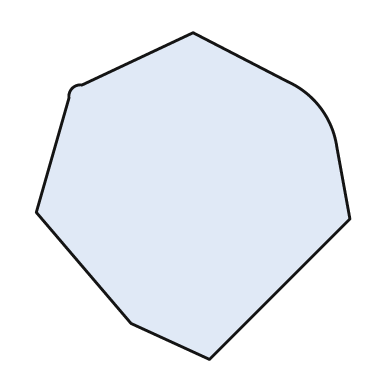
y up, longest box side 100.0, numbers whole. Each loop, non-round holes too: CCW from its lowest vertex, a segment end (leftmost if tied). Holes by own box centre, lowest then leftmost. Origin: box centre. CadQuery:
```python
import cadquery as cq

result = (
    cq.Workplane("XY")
    .moveTo(5.0, -50.0)
    .lineTo(48.0, -7.0)
    .lineTo(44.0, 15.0)
    .threePointArc((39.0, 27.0), (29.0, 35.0))
    .lineTo(0.0, 50.0)
    .lineTo(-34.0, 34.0)
    .threePointArc((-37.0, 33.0), (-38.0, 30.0))
    .lineTo(-48.0, -5.0)
    .lineTo(-19.0, -39.0)
    .close()
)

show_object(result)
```